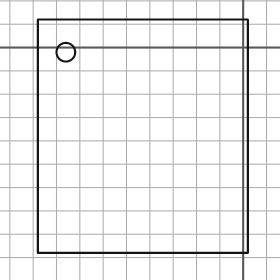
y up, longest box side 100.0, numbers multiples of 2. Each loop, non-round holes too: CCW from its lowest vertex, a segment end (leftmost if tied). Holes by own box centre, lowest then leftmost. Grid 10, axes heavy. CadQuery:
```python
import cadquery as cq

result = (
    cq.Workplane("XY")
    .moveTo(-88.0, -88.0)
    .lineTo(2.0, -88.0)
    .lineTo(2.0, 12.0)
    .lineTo(-88.0, 12.0)
    .close()
    .moveTo(-76.0, -2.0)
    .circle(4.0)
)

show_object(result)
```